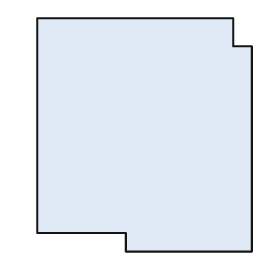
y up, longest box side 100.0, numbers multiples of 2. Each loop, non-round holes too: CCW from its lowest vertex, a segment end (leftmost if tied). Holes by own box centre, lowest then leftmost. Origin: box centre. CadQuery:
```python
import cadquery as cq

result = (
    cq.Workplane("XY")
    .moveTo(-8.0, -50.0)
    .lineTo(46.0, -50.0)
    .lineTo(46.0, 38.0)
    .lineTo(38.0, 38.0)
    .lineTo(38.0, 50.0)
    .lineTo(-46.0, 50.0)
    .lineTo(-46.0, -42.0)
    .lineTo(-8.0, -42.0)
    .close()
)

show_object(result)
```